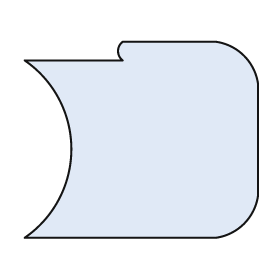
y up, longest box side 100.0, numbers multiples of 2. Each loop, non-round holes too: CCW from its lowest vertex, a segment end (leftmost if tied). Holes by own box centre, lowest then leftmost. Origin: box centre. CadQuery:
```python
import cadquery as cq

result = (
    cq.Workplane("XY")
    .moveTo(-50.0, -42.0)
    .lineTo(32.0, -42.0)
    .threePointArc((44.0, -36.0), (50.0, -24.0))
    .lineTo(50.0, 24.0)
    .threePointArc((44.0, 36.0), (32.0, 42.0))
    .lineTo(-8.0, 42.0)
    .threePointArc((-10.0, 38.0), (-8.0, 34.0))
    .lineTo(-50.0, 34.0)
    .threePointArc((-30.0, -4.0), (-50.0, -42.0))
    .close()
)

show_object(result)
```